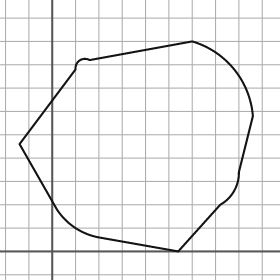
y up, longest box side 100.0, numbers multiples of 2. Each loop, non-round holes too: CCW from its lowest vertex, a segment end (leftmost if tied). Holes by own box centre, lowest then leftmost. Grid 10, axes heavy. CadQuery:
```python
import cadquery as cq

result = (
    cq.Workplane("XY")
    .moveTo(54.0, 0.0)
    .lineTo(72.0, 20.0)
    .threePointArc((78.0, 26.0), (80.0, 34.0))
    .lineTo(86.0, 58.0)
    .threePointArc((78.0, 78.0), (60.0, 90.0))
    .lineTo(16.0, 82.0)
    .threePointArc((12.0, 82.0), (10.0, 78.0))
    .lineTo(-14.0, 46.0)
    .lineTo(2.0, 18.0)
    .threePointArc((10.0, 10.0), (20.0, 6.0))
    .close()
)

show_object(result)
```